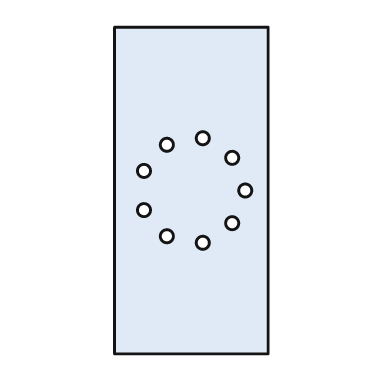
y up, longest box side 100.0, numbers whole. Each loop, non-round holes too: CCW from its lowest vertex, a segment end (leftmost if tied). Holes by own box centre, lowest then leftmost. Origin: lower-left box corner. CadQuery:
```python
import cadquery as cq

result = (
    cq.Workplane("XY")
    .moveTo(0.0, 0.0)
    .lineTo(47.0, 0.0)
    .lineTo(47.0, 100.0)
    .lineTo(0.0, 100.0)
    .close()
    .moveTo(27.0, 34.0)
    .circle(2.0)
    .moveTo(16.0, 36.0)
    .circle(2.0)
    .moveTo(36.0, 40.0)
    .circle(2.0)
    .moveTo(9.0, 44.0)
    .circle(2.0)
    .moveTo(40.0, 50.0)
    .circle(2.0)
    .moveTo(9.0, 56.0)
    .circle(2.0)
    .moveTo(36.0, 60.0)
    .circle(2.0)
    .moveTo(16.0, 64.0)
    .circle(2.0)
    .moveTo(27.0, 66.0)
    .circle(2.0)
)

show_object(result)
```